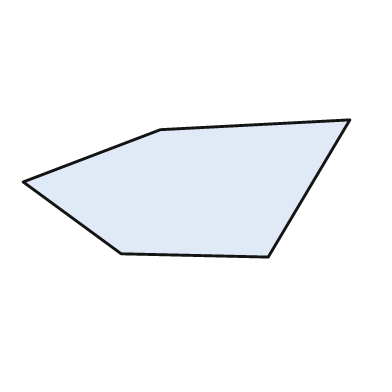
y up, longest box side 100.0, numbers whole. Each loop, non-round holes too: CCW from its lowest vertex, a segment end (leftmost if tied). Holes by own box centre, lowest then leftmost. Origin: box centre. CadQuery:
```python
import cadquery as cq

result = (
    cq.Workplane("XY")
    .moveTo(25.0, -21.0)
    .lineTo(50.0, 21.0)
    .lineTo(-8.0, 18.0)
    .lineTo(-50.0, 2.0)
    .lineTo(-20.0, -20.0)
    .close()
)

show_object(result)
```